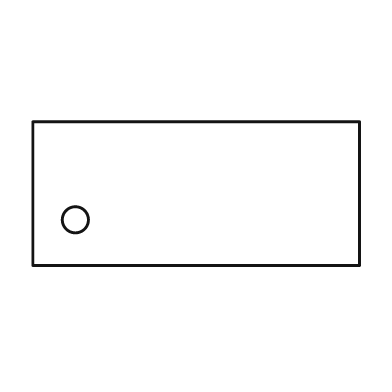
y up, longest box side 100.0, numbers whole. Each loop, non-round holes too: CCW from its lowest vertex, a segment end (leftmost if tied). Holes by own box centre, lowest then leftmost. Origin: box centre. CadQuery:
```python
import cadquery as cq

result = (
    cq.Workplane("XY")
    .moveTo(-50.0, -22.0)
    .lineTo(50.0, -22.0)
    .lineTo(50.0, 22.0)
    .lineTo(-50.0, 22.0)
    .close()
    .moveTo(-37.0, -8.0)
    .circle(4.0)
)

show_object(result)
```